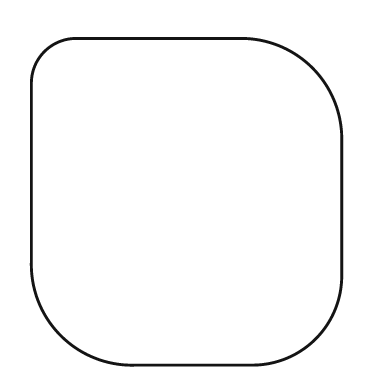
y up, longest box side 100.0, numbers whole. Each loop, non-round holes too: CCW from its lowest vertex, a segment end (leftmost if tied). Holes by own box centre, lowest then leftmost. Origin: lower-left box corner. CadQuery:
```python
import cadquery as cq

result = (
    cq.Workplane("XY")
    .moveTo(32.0, 0.0)
    .lineTo(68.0, 0.0)
    .threePointArc((87.0, 8.0), (95.0, 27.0))
    .lineTo(95.0, 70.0)
    .threePointArc((86.0, 91.0), (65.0, 100.0))
    .lineTo(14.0, 100.0)
    .threePointArc((4.0, 96.0), (0.0, 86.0))
    .lineTo(0.0, 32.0)
    .threePointArc((9.0, 9.0), (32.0, 0.0))
    .close()
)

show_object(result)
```